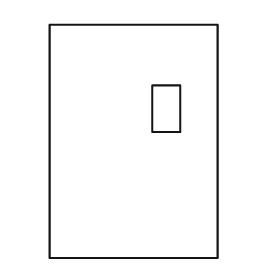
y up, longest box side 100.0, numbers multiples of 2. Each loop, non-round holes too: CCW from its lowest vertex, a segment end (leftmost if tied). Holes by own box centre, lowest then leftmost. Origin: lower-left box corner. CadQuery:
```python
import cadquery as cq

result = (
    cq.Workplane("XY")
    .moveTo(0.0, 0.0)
    .lineTo(72.0, 0.0)
    .lineTo(72.0, 100.0)
    .lineTo(0.0, 100.0)
    .close()
    .moveTo(44.0, 54.0)
    .lineTo(56.0, 54.0)
    .lineTo(56.0, 74.0)
    .lineTo(44.0, 74.0)
    .close()
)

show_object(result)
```